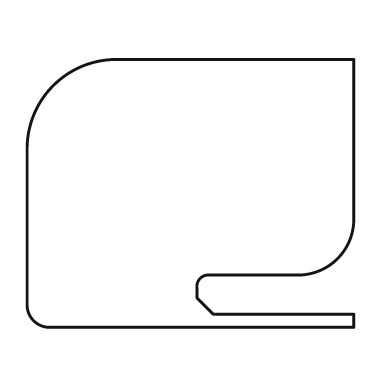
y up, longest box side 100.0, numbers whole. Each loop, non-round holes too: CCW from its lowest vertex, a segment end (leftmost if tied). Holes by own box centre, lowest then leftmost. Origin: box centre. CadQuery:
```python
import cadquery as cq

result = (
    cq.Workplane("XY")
    .moveTo(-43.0, -41.0)
    .lineTo(50.0, -41.0)
    .lineTo(50.0, -37.0)
    .lineTo(7.0, -37.0)
    .lineTo(2.0, -32.0)
    .lineTo(2.0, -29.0)
    .threePointArc((3.0, -26.0), (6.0, -25.0))
    .lineTo(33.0, -25.0)
    .threePointArc((45.0, -20.0), (50.0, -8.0))
    .lineTo(50.0, 41.0)
    .lineTo(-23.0, 41.0)
    .threePointArc((-42.0, 33.0), (-50.0, 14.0))
    .lineTo(-50.0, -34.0)
    .threePointArc((-48.0, -39.0), (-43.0, -41.0))
    .close()
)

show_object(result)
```